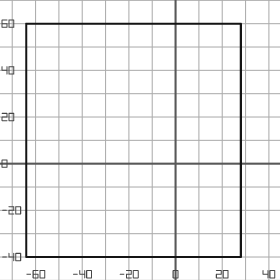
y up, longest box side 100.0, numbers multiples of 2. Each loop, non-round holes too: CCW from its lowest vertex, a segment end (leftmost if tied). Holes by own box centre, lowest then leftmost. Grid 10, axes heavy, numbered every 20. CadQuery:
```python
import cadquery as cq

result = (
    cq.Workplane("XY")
    .moveTo(-64.0, -40.0)
    .lineTo(28.0, -40.0)
    .lineTo(28.0, 60.0)
    .lineTo(-64.0, 60.0)
    .close()
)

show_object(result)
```